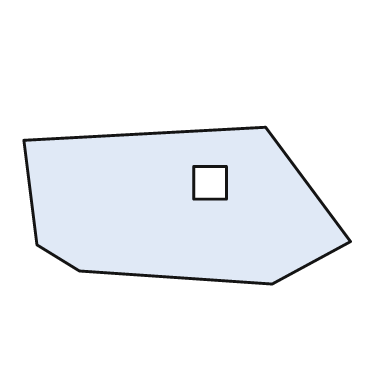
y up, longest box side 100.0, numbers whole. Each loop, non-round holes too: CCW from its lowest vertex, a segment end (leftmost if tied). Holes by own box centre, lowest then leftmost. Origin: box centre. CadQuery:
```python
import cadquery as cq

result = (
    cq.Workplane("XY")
    .moveTo(26.0, -24.0)
    .lineTo(50.0, -11.0)
    .lineTo(24.0, 24.0)
    .lineTo(-50.0, 20.0)
    .lineTo(-46.0, -12.0)
    .lineTo(-33.0, -20.0)
    .close()
    .moveTo(2.0, 2.0)
    .lineTo(12.0, 2.0)
    .lineTo(12.0, 12.0)
    .lineTo(2.0, 12.0)
    .close()
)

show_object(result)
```